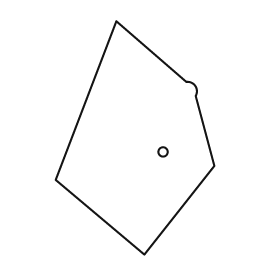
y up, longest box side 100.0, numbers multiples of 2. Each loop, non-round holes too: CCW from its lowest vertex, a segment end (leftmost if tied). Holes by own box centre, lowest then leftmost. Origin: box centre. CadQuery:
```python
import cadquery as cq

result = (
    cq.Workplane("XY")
    .moveTo(4.0, -50.0)
    .lineTo(34.0, -12.0)
    .lineTo(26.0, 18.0)
    .threePointArc((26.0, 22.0), (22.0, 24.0))
    .lineTo(-8.0, 50.0)
    .lineTo(-34.0, -18.0)
    .close()
    .moveTo(12.0, -6.0)
    .circle(2.0)
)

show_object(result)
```